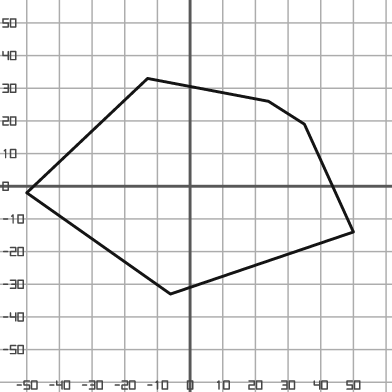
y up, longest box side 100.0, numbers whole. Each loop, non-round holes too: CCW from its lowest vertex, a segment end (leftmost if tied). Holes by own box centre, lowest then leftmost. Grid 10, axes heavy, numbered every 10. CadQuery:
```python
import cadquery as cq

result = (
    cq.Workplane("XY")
    .moveTo(-6.0, -33.0)
    .lineTo(50.0, -14.0)
    .lineTo(35.0, 19.0)
    .lineTo(24.0, 26.0)
    .lineTo(-13.0, 33.0)
    .lineTo(-50.0, -2.0)
    .close()
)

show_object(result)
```